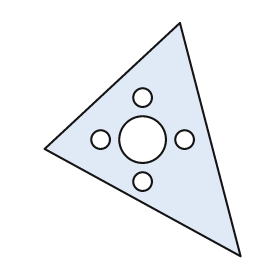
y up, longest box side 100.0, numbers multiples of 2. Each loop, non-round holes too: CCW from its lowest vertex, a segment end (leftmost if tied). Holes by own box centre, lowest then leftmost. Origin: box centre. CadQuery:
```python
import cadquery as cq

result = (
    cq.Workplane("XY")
    .moveTo(42.0, -50.0)
    .lineTo(16.0, 50.0)
    .lineTo(-42.0, -4.0)
    .close()
    .moveTo(0.0, -18.0)
    .circle(4.0)
    .moveTo(-18.0, 0.0)
    .circle(4.0)
    .moveTo(0.0, 0.0)
    .circle(10.0)
    .moveTo(18.0, 0.0)
    .circle(4.0)
    .moveTo(0.0, 18.0)
    .circle(4.0)
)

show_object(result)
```